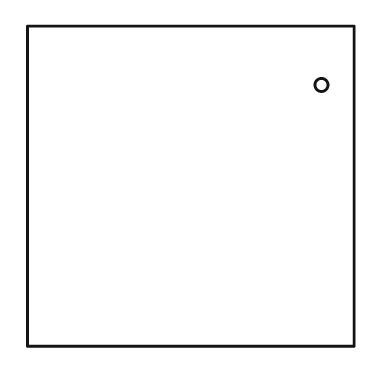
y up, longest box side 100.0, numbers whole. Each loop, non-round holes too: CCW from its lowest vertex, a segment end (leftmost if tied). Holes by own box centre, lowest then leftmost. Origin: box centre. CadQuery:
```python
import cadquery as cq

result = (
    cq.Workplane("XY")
    .moveTo(-50.0, -49.0)
    .lineTo(50.0, -49.0)
    .lineTo(50.0, 49.0)
    .lineTo(-50.0, 49.0)
    .close()
    .moveTo(40.0, 31.0)
    .circle(2.0)
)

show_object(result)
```